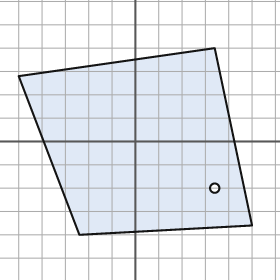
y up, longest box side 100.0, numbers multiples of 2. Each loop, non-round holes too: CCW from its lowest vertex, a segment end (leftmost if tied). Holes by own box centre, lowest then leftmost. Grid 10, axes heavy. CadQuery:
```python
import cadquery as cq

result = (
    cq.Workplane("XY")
    .moveTo(-24.0, -40.0)
    .lineTo(50.0, -36.0)
    .lineTo(34.0, 40.0)
    .lineTo(-50.0, 28.0)
    .close()
    .moveTo(34.0, -20.0)
    .circle(2.0)
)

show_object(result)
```